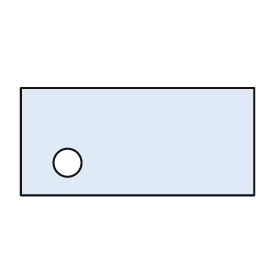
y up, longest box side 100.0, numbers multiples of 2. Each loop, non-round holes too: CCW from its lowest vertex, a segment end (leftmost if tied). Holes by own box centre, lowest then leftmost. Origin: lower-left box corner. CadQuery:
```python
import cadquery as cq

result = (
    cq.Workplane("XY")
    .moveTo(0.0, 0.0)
    .lineTo(100.0, 0.0)
    .lineTo(100.0, 46.0)
    .lineTo(0.0, 46.0)
    .close()
    .moveTo(20.0, 14.0)
    .circle(6.0)
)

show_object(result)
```